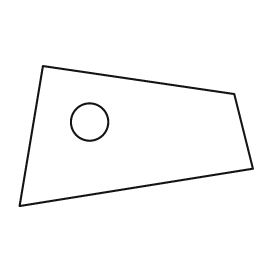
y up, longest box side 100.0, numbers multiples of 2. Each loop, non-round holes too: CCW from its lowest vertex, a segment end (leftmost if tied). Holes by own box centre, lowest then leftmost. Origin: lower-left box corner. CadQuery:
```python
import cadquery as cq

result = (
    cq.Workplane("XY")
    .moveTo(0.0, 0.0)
    .lineTo(100.0, 16.0)
    .lineTo(92.0, 48.0)
    .lineTo(10.0, 60.0)
    .close()
    .moveTo(30.0, 36.0)
    .circle(8.0)
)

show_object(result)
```